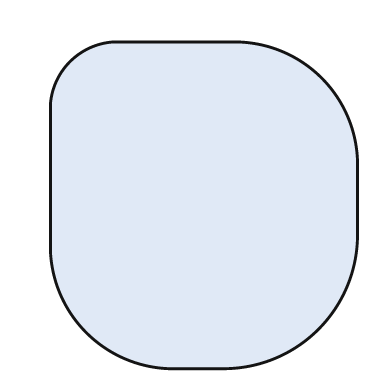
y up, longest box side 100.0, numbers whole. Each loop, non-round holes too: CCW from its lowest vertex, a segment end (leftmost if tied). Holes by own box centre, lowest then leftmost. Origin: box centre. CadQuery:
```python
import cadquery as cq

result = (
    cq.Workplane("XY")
    .moveTo(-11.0, -50.0)
    .lineTo(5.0, -50.0)
    .threePointArc((35.0, -38.0), (47.0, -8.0))
    .lineTo(47.0, 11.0)
    .threePointArc((36.0, 39.0), (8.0, 50.0))
    .lineTo(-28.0, 50.0)
    .threePointArc((-41.0, 44.0), (-47.0, 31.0))
    .lineTo(-47.0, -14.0)
    .threePointArc((-36.0, -39.0), (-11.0, -50.0))
    .close()
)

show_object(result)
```